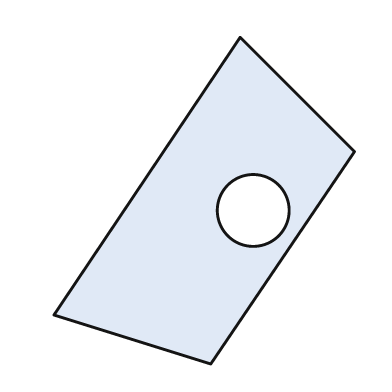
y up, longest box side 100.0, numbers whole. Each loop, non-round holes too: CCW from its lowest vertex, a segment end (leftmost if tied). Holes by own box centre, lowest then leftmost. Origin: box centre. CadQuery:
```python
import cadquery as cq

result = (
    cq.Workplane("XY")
    .moveTo(2.0, -50.0)
    .lineTo(46.0, 15.0)
    .lineTo(11.0, 50.0)
    .lineTo(-46.0, -35.0)
    .close()
    .moveTo(15.0, -3.0)
    .circle(11.0)
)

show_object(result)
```